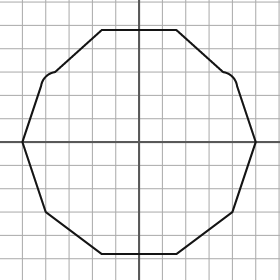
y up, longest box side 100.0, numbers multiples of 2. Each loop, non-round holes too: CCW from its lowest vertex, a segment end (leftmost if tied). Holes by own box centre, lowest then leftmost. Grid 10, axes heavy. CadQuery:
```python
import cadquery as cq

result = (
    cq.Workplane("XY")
    .moveTo(-16.0, -48.0)
    .lineTo(16.0, -48.0)
    .lineTo(40.0, -30.0)
    .lineTo(50.0, 0.0)
    .lineTo(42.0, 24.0)
    .threePointArc((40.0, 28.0), (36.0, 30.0))
    .lineTo(16.0, 48.0)
    .lineTo(-16.0, 48.0)
    .lineTo(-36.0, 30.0)
    .threePointArc((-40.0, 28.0), (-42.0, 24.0))
    .lineTo(-50.0, 0.0)
    .lineTo(-40.0, -30.0)
    .close()
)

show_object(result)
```